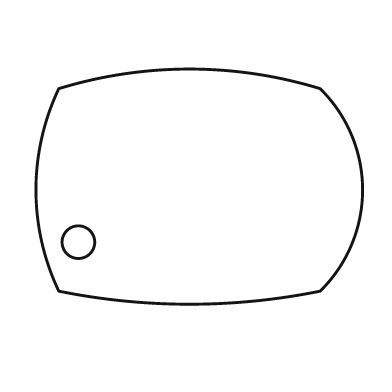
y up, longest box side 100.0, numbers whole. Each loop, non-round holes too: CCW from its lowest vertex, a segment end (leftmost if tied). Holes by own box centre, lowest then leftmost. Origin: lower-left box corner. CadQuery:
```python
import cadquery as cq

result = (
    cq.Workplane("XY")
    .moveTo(7.0, 4.0)
    .threePointArc((47.0, 0.0), (87.0, 4.0))
    .threePointArc((100.0, 35.0), (87.0, 66.0))
    .threePointArc((47.0, 72.0), (7.0, 66.0))
    .threePointArc((0.0, 35.0), (7.0, 4.0))
    .close()
    .moveTo(13.0, 19.0)
    .circle(5.0)
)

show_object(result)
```